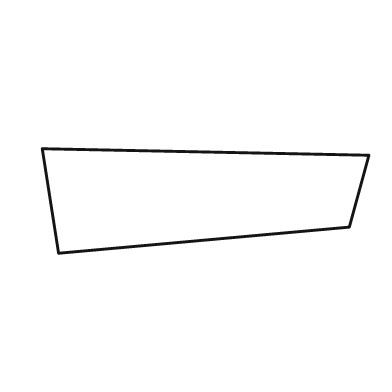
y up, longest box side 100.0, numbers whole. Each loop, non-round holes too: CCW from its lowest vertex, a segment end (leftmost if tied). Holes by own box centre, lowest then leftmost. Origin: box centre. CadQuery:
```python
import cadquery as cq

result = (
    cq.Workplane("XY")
    .moveTo(-45.0, -16.0)
    .lineTo(44.0, -8.0)
    .lineTo(50.0, 14.0)
    .lineTo(-50.0, 16.0)
    .close()
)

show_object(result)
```